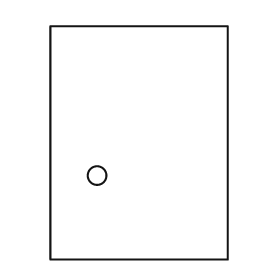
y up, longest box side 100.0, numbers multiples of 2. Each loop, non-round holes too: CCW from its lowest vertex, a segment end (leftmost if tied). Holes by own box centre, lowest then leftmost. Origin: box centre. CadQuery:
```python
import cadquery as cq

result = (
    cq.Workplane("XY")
    .moveTo(-38.0, -50.0)
    .lineTo(38.0, -50.0)
    .lineTo(38.0, 50.0)
    .lineTo(-38.0, 50.0)
    .close()
    .moveTo(-18.0, -14.0)
    .circle(4.0)
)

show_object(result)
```